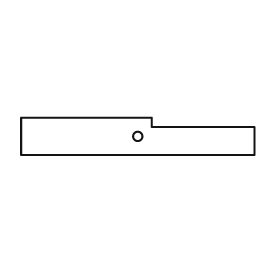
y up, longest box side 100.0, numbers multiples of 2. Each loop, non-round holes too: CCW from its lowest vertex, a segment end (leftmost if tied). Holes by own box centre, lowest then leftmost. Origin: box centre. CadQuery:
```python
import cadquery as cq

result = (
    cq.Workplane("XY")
    .moveTo(-50.0, -8.0)
    .lineTo(50.0, -8.0)
    .lineTo(50.0, 4.0)
    .lineTo(6.0, 4.0)
    .lineTo(6.0, 8.0)
    .lineTo(-50.0, 8.0)
    .close()
    .moveTo(0.0, 0.0)
    .circle(2.0)
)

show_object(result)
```